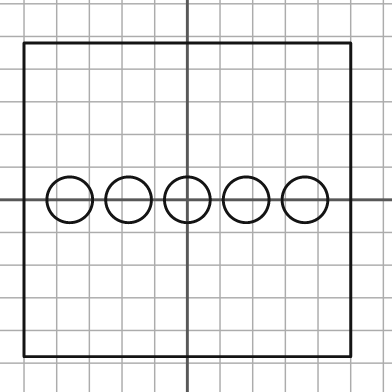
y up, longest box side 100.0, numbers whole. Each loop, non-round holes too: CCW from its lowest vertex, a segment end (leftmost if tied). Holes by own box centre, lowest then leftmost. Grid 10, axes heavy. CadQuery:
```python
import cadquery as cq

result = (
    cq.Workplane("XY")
    .moveTo(-50.0, -48.0)
    .lineTo(50.0, -48.0)
    .lineTo(50.0, 48.0)
    .lineTo(-50.0, 48.0)
    .close()
    .moveTo(-36.0, 0.0)
    .circle(7.0)
    .moveTo(-18.0, 0.0)
    .circle(7.0)
    .moveTo(0.0, 0.0)
    .circle(7.0)
    .moveTo(18.0, 0.0)
    .circle(7.0)
    .moveTo(36.0, 0.0)
    .circle(7.0)
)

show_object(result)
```